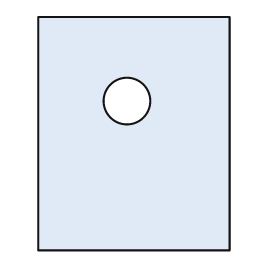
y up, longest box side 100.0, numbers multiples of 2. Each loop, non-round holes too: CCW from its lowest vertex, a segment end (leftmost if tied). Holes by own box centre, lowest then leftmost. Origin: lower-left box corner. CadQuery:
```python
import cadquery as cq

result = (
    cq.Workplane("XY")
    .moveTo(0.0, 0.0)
    .lineTo(82.0, 0.0)
    .lineTo(82.0, 100.0)
    .lineTo(0.0, 100.0)
    .close()
    .moveTo(38.0, 64.0)
    .circle(10.0)
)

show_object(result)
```